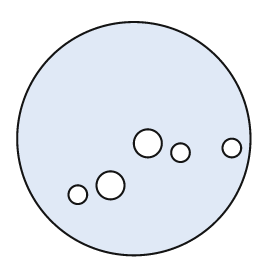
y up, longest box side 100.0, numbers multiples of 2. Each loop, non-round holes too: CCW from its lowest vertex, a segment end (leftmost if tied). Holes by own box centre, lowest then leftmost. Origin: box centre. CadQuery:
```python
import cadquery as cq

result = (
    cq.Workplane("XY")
    .moveTo(0.0, 0.0)
    .circle(50.0)
    .moveTo(-24.0, -24.0)
    .circle(4.0)
    .moveTo(-10.0, -20.0)
    .circle(6.0)
    .moveTo(20.0, -6.0)
    .circle(4.0)
    .moveTo(42.0, -4.0)
    .circle(4.0)
    .moveTo(6.0, -2.0)
    .circle(6.0)
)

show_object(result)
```